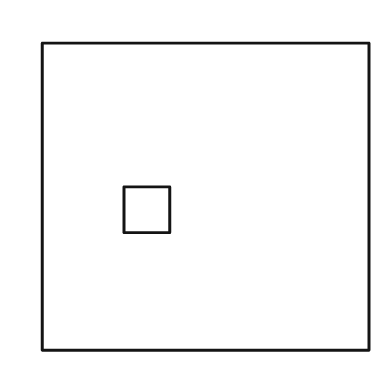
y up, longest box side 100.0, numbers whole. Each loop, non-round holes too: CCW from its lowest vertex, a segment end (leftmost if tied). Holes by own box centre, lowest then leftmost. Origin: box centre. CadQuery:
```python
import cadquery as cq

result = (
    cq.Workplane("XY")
    .moveTo(-50.0, -47.0)
    .lineTo(50.0, -47.0)
    .lineTo(50.0, 47.0)
    .lineTo(-50.0, 47.0)
    .close()
    .moveTo(-25.0, -11.0)
    .lineTo(-11.0, -11.0)
    .lineTo(-11.0, 3.0)
    .lineTo(-25.0, 3.0)
    .close()
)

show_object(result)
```